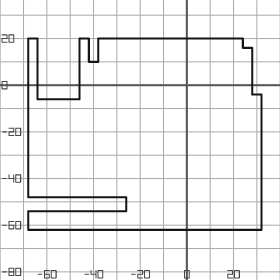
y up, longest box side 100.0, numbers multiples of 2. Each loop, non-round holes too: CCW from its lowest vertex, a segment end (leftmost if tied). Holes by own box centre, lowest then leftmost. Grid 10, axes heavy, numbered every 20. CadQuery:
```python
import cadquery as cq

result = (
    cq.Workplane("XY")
    .moveTo(-68.0, -62.0)
    .lineTo(32.0, -62.0)
    .lineTo(32.0, -4.0)
    .lineTo(28.0, -4.0)
    .lineTo(28.0, 16.0)
    .lineTo(24.0, 16.0)
    .lineTo(24.0, 20.0)
    .lineTo(-38.0, 20.0)
    .lineTo(-38.0, 10.0)
    .lineTo(-42.0, 10.0)
    .lineTo(-42.0, 20.0)
    .lineTo(-46.0, 20.0)
    .lineTo(-46.0, -6.0)
    .lineTo(-64.0, -6.0)
    .lineTo(-64.0, 20.0)
    .lineTo(-68.0, 20.0)
    .lineTo(-68.0, -48.0)
    .lineTo(-26.0, -48.0)
    .lineTo(-26.0, -54.0)
    .lineTo(-68.0, -54.0)
    .close()
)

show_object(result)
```